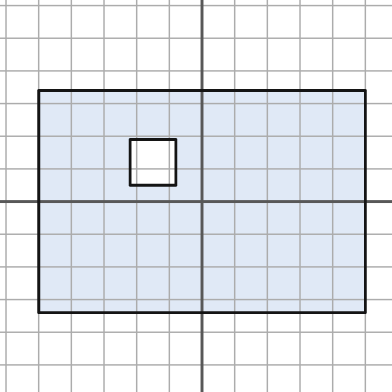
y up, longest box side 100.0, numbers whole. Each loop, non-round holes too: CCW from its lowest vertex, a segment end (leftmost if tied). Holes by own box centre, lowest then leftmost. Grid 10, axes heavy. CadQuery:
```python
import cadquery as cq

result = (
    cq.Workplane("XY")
    .moveTo(-50.0, -34.0)
    .lineTo(50.0, -34.0)
    .lineTo(50.0, 34.0)
    .lineTo(-50.0, 34.0)
    .close()
    .moveTo(-22.0, 5.0)
    .lineTo(-8.0, 5.0)
    .lineTo(-8.0, 19.0)
    .lineTo(-22.0, 19.0)
    .close()
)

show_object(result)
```